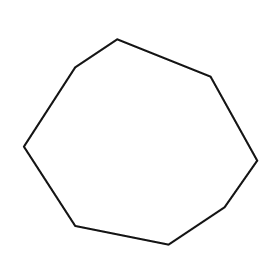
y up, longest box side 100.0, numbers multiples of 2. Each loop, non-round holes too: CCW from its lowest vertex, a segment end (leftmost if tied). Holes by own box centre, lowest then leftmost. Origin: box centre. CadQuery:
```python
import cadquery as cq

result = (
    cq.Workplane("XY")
    .moveTo(12.0, -44.0)
    .lineTo(36.0, -28.0)
    .lineTo(50.0, -8.0)
    .lineTo(30.0, 28.0)
    .lineTo(-10.0, 44.0)
    .lineTo(-28.0, 32.0)
    .lineTo(-50.0, -2.0)
    .lineTo(-28.0, -36.0)
    .close()
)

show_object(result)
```